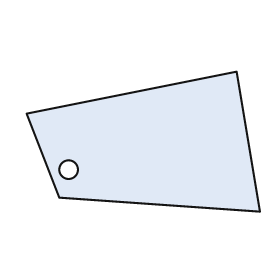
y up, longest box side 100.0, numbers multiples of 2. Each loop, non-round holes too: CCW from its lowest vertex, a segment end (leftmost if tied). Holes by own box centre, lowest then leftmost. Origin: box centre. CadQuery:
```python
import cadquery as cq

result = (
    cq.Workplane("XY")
    .moveTo(50.0, -30.0)
    .lineTo(40.0, 30.0)
    .lineTo(-50.0, 12.0)
    .lineTo(-36.0, -24.0)
    .close()
    .moveTo(-32.0, -12.0)
    .circle(4.0)
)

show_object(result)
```